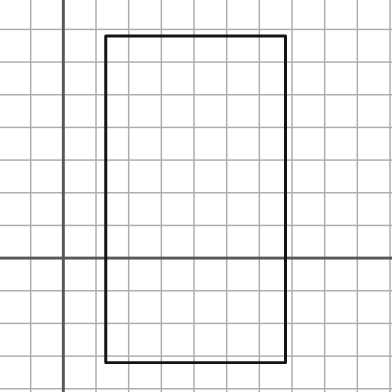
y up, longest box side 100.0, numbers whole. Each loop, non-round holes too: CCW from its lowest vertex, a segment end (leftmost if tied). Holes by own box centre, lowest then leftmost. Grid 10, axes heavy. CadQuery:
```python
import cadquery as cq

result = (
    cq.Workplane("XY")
    .moveTo(13.0, -32.0)
    .lineTo(68.0, -32.0)
    .lineTo(68.0, 68.0)
    .lineTo(13.0, 68.0)
    .close()
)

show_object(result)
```